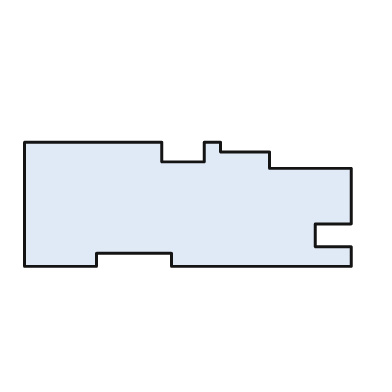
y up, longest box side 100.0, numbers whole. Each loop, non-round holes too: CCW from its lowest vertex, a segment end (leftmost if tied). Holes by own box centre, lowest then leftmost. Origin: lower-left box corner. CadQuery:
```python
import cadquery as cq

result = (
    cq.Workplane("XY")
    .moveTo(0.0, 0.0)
    .lineTo(22.0, 0.0)
    .lineTo(22.0, 4.0)
    .lineTo(45.0, 4.0)
    .lineTo(45.0, 0.0)
    .lineTo(100.0, 0.0)
    .lineTo(100.0, 6.0)
    .lineTo(89.0, 6.0)
    .lineTo(89.0, 13.0)
    .lineTo(100.0, 13.0)
    .lineTo(100.0, 30.0)
    .lineTo(75.0, 30.0)
    .lineTo(75.0, 35.0)
    .lineTo(60.0, 35.0)
    .lineTo(60.0, 38.0)
    .lineTo(55.0, 38.0)
    .lineTo(55.0, 32.0)
    .lineTo(42.0, 32.0)
    .lineTo(42.0, 38.0)
    .lineTo(0.0, 38.0)
    .close()
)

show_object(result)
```